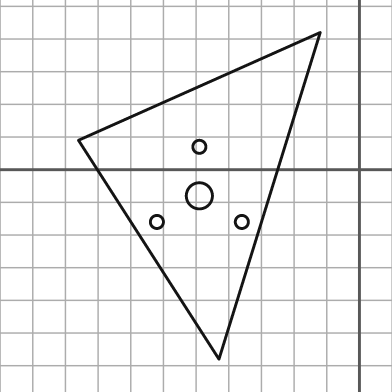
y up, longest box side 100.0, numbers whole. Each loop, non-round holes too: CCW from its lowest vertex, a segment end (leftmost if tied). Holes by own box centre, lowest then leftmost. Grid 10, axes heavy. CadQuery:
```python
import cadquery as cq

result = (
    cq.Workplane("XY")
    .moveTo(-43.0, -58.0)
    .lineTo(-12.0, 42.0)
    .lineTo(-86.0, 9.0)
    .close()
    .moveTo(-62.0, -16.0)
    .circle(2.0)
    .moveTo(-36.0, -16.0)
    .circle(2.0)
    .moveTo(-49.0, -8.0)
    .circle(4.0)
    .moveTo(-49.0, 7.0)
    .circle(2.0)
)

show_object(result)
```